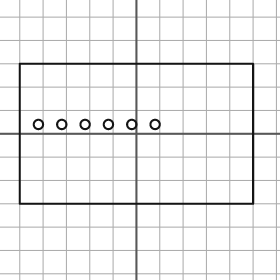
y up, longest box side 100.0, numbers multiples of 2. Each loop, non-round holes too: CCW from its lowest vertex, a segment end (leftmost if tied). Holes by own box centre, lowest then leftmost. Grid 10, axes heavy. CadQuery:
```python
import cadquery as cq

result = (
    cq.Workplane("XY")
    .moveTo(-50.0, -30.0)
    .lineTo(50.0, -30.0)
    .lineTo(50.0, 30.0)
    .lineTo(-50.0, 30.0)
    .close()
    .moveTo(-42.0, 4.0)
    .circle(2.0)
    .moveTo(-32.0, 4.0)
    .circle(2.0)
    .moveTo(-22.0, 4.0)
    .circle(2.0)
    .moveTo(-12.0, 4.0)
    .circle(2.0)
    .moveTo(-2.0, 4.0)
    .circle(2.0)
    .moveTo(8.0, 4.0)
    .circle(2.0)
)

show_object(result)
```